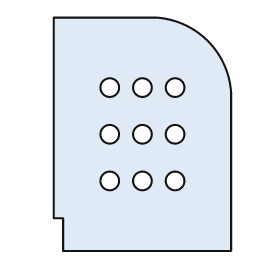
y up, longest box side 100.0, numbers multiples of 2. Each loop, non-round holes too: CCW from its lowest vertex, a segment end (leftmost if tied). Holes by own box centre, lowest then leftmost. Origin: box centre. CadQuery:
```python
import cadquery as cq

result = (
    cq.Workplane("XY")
    .moveTo(-34.0, -50.0)
    .lineTo(38.0, -50.0)
    .lineTo(38.0, 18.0)
    .threePointArc((28.0, 40.0), (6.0, 50.0))
    .lineTo(-38.0, 50.0)
    .lineTo(-38.0, -36.0)
    .lineTo(-34.0, -36.0)
    .close()
    .moveTo(-14.0, -20.0)
    .circle(4.0)
    .moveTo(0.0, -20.0)
    .circle(4.0)
    .moveTo(14.0, -20.0)
    .circle(4.0)
    .moveTo(-14.0, 0.0)
    .circle(4.0)
    .moveTo(0.0, 0.0)
    .circle(4.0)
    .moveTo(14.0, 0.0)
    .circle(4.0)
    .moveTo(-14.0, 20.0)
    .circle(4.0)
    .moveTo(0.0, 20.0)
    .circle(4.0)
    .moveTo(14.0, 20.0)
    .circle(4.0)
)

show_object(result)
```